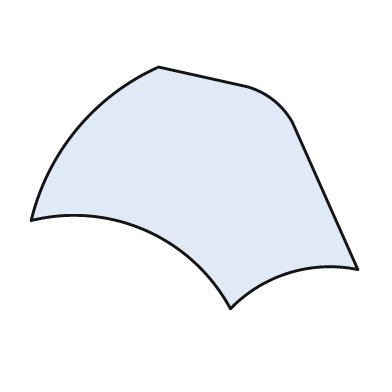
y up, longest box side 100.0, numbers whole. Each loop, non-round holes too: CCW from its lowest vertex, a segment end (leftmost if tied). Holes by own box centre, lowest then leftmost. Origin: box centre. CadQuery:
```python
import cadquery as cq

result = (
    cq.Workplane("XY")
    .moveTo(11.0, -37.0)
    .threePointArc((29.0, -26.0), (50.0, -25.0))
    .lineTo(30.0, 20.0)
    .threePointArc((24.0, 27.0), (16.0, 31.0))
    .lineTo(-11.0, 37.0)
    .threePointArc((-36.0, 18.0), (-50.0, -10.0))
    .threePointArc((-15.0, -13.0), (11.0, -37.0))
    .close()
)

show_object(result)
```